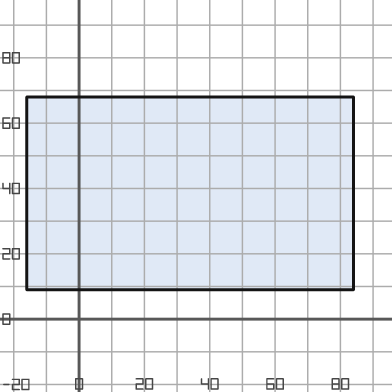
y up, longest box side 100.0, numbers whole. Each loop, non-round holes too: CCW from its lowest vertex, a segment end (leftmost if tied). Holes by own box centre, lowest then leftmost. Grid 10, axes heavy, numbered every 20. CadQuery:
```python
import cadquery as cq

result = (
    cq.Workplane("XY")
    .moveTo(-16.0, 9.0)
    .lineTo(84.0, 9.0)
    .lineTo(84.0, 68.0)
    .lineTo(-16.0, 68.0)
    .close()
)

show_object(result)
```